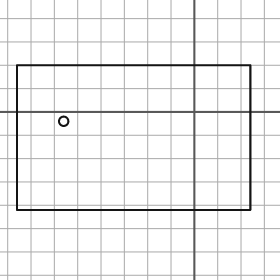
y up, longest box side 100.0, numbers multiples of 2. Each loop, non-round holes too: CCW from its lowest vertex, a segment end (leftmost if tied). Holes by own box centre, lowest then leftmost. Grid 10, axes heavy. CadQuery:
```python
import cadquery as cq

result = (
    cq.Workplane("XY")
    .moveTo(-76.0, -42.0)
    .lineTo(24.0, -42.0)
    .lineTo(24.0, 20.0)
    .lineTo(-76.0, 20.0)
    .close()
    .moveTo(-56.0, -4.0)
    .circle(2.0)
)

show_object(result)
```